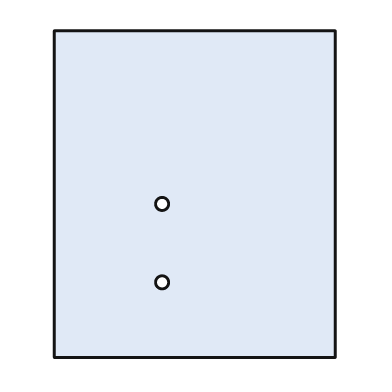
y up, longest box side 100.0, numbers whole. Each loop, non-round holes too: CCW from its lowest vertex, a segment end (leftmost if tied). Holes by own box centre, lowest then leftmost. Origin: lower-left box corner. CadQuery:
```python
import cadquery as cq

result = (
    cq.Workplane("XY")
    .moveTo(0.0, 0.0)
    .lineTo(86.0, 0.0)
    .lineTo(86.0, 100.0)
    .lineTo(0.0, 100.0)
    .close()
    .moveTo(33.0, 23.0)
    .circle(2.0)
    .moveTo(33.0, 47.0)
    .circle(2.0)
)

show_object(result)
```